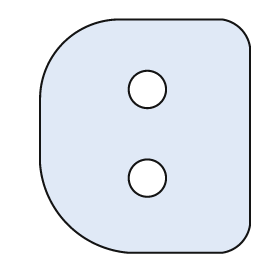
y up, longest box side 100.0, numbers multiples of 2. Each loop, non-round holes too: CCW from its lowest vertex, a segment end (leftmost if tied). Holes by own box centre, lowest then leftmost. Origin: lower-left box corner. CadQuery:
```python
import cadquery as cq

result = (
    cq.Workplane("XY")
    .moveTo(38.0, 0.0)
    .lineTo(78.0, 0.0)
    .threePointArc((86.0, 4.0), (90.0, 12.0))
    .lineTo(90.0, 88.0)
    .threePointArc((86.0, 96.0), (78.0, 100.0))
    .lineTo(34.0, 100.0)
    .threePointArc((10.0, 90.0), (0.0, 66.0))
    .lineTo(0.0, 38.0)
    .threePointArc((12.0, 12.0), (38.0, 0.0))
    .close()
    .moveTo(46.0, 32.0)
    .circle(8.0)
    .moveTo(46.0, 70.0)
    .circle(8.0)
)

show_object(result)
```